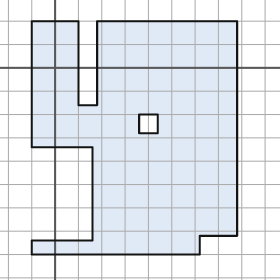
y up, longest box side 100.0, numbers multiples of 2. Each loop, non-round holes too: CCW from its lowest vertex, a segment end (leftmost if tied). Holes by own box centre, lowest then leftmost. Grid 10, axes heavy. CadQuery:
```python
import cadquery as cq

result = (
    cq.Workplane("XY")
    .moveTo(-10.0, -80.0)
    .lineTo(62.0, -80.0)
    .lineTo(62.0, -72.0)
    .lineTo(78.0, -72.0)
    .lineTo(78.0, 20.0)
    .lineTo(18.0, 20.0)
    .lineTo(18.0, -16.0)
    .lineTo(10.0, -16.0)
    .lineTo(10.0, 20.0)
    .lineTo(-10.0, 20.0)
    .lineTo(-10.0, -34.0)
    .lineTo(16.0, -34.0)
    .lineTo(16.0, -74.0)
    .lineTo(-10.0, -74.0)
    .close()
    .moveTo(36.0, -28.0)
    .lineTo(44.0, -28.0)
    .lineTo(44.0, -20.0)
    .lineTo(36.0, -20.0)
    .close()
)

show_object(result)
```